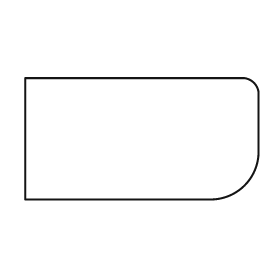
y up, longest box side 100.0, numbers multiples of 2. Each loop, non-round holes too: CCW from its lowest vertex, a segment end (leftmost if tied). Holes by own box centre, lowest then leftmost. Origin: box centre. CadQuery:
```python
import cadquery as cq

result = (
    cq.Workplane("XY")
    .moveTo(-50.0, -26.0)
    .lineTo(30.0, -26.0)
    .threePointArc((44.0, -20.0), (50.0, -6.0))
    .lineTo(50.0, 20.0)
    .threePointArc((48.0, 24.0), (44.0, 26.0))
    .lineTo(-50.0, 26.0)
    .close()
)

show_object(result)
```